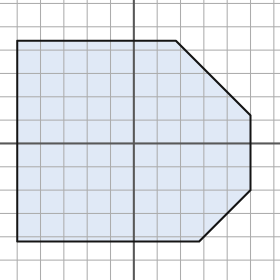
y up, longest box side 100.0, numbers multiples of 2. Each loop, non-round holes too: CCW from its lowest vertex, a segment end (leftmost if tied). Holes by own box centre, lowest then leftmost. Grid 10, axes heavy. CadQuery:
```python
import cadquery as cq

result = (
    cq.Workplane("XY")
    .moveTo(-50.0, -42.0)
    .lineTo(28.0, -42.0)
    .lineTo(50.0, -20.0)
    .lineTo(50.0, 12.0)
    .lineTo(18.0, 44.0)
    .lineTo(-50.0, 44.0)
    .close()
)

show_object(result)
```